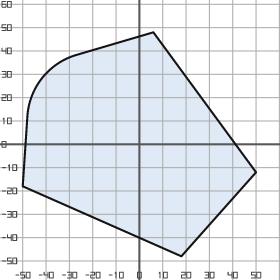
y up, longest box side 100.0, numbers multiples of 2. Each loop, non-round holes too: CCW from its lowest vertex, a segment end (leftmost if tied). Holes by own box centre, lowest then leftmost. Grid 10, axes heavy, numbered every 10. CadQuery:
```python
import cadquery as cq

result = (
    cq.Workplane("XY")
    .moveTo(18.0, -48.0)
    .lineTo(50.0, -12.0)
    .lineTo(6.0, 48.0)
    .lineTo(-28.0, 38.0)
    .threePointArc((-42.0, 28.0), (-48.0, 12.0))
    .lineTo(-50.0, -18.0)
    .close()
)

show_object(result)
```